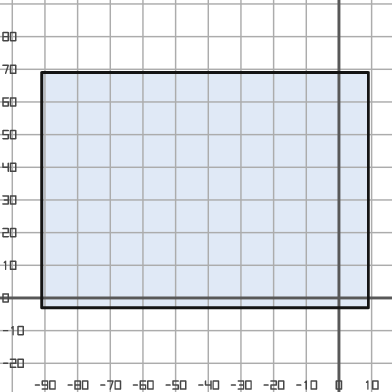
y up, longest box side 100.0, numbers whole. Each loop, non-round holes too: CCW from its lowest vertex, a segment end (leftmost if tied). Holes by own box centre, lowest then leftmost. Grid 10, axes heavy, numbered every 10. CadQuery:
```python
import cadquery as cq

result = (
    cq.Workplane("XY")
    .moveTo(-91.0, -3.0)
    .lineTo(9.0, -3.0)
    .lineTo(9.0, 69.0)
    .lineTo(-91.0, 69.0)
    .close()
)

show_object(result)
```